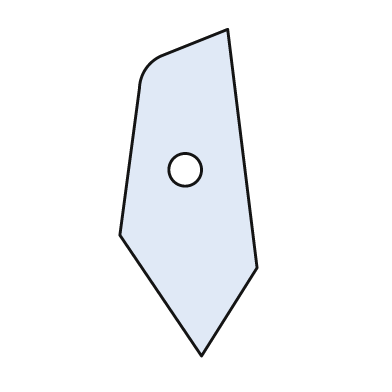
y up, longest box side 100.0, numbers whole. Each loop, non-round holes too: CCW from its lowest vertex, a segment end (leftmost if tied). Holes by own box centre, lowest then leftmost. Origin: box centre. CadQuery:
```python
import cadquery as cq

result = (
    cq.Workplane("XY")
    .moveTo(4.0, -50.0)
    .lineTo(21.0, -23.0)
    .lineTo(12.0, 50.0)
    .lineTo(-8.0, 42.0)
    .threePointArc((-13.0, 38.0), (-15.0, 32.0))
    .lineTo(-21.0, -13.0)
    .close()
    .moveTo(-1.0, 7.0)
    .circle(5.0)
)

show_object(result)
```